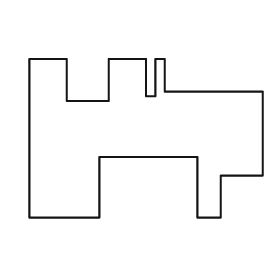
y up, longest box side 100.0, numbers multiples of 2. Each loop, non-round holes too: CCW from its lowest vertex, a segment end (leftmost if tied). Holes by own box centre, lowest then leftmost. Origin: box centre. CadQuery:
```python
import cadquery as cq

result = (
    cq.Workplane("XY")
    .moveTo(-50.0, -34.0)
    .lineTo(-20.0, -34.0)
    .lineTo(-20.0, -8.0)
    .lineTo(22.0, -8.0)
    .lineTo(22.0, -34.0)
    .lineTo(32.0, -34.0)
    .lineTo(32.0, -16.0)
    .lineTo(50.0, -16.0)
    .lineTo(50.0, 20.0)
    .lineTo(8.0, 20.0)
    .lineTo(8.0, 34.0)
    .lineTo(4.0, 34.0)
    .lineTo(4.0, 18.0)
    .lineTo(0.0, 18.0)
    .lineTo(0.0, 34.0)
    .lineTo(-16.0, 34.0)
    .lineTo(-16.0, 16.0)
    .lineTo(-34.0, 16.0)
    .lineTo(-34.0, 34.0)
    .lineTo(-50.0, 34.0)
    .close()
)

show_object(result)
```